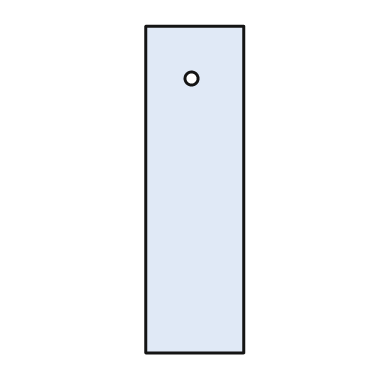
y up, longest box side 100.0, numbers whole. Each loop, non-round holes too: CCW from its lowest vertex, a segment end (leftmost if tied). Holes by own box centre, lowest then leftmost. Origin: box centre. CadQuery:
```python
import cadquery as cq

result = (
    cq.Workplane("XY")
    .moveTo(-15.0, -50.0)
    .lineTo(15.0, -50.0)
    .lineTo(15.0, 50.0)
    .lineTo(-15.0, 50.0)
    .close()
    .moveTo(-1.0, 34.0)
    .circle(2.0)
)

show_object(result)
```